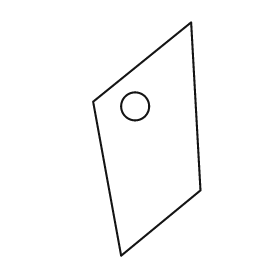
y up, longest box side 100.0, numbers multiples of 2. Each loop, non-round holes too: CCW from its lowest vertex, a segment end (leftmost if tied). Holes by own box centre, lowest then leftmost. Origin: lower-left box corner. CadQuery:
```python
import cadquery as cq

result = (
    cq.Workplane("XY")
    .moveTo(12.0, 0.0)
    .lineTo(46.0, 28.0)
    .lineTo(42.0, 100.0)
    .lineTo(0.0, 66.0)
    .close()
    .moveTo(18.0, 64.0)
    .circle(6.0)
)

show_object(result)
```